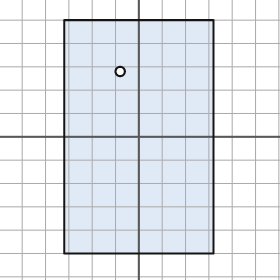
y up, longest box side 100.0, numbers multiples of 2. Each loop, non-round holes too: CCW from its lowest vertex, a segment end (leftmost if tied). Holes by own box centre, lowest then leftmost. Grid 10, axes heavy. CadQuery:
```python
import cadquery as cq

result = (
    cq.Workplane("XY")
    .moveTo(-32.0, -50.0)
    .lineTo(32.0, -50.0)
    .lineTo(32.0, 50.0)
    .lineTo(-32.0, 50.0)
    .close()
    .moveTo(-8.0, 28.0)
    .circle(2.0)
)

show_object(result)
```